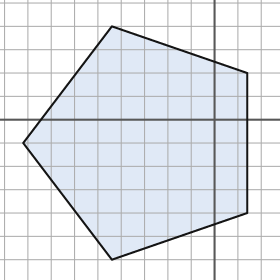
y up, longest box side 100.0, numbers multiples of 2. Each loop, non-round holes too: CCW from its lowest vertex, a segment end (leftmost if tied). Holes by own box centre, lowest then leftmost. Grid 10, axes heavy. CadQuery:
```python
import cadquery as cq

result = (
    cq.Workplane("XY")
    .moveTo(-44.0, -60.0)
    .lineTo(14.0, -40.0)
    .lineTo(14.0, 20.0)
    .lineTo(-44.0, 40.0)
    .lineTo(-82.0, -10.0)
    .close()
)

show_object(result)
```